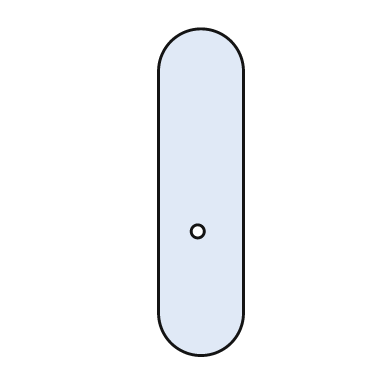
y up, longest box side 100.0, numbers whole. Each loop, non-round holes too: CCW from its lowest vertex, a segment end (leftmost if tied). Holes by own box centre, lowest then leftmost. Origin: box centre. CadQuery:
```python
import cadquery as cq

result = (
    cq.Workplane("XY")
    .moveTo(-13.0, -37.0)
    .threePointArc((0.0, -50.0), (13.0, -37.0))
    .lineTo(13.0, 37.0)
    .threePointArc((0.0, 50.0), (-13.0, 37.0))
    .close()
    .moveTo(-1.0, -12.0)
    .circle(2.0)
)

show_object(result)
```